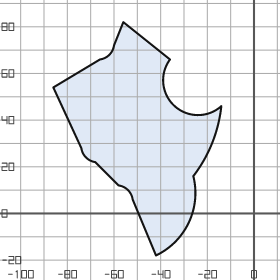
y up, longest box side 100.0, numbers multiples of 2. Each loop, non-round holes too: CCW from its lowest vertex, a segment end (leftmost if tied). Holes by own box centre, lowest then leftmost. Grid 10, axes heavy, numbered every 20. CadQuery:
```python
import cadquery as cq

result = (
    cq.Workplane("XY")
    .moveTo(-42.0, -18.0)
    .threePointArc((-28.0, -4.0), (-26.0, 16.0))
    .threePointArc((-18.0, 30.0), (-14.0, 46.0))
    .threePointArc((-34.0, 46.0), (-36.0, 66.0))
    .lineTo(-56.0, 82.0)
    .lineTo(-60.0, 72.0)
    .threePointArc((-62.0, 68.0), (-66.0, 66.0))
    .lineTo(-86.0, 54.0)
    .lineTo(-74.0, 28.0)
    .threePointArc((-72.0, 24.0), (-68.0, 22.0))
    .lineTo(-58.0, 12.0)
    .threePointArc((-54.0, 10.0), (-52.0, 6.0))
    .close()
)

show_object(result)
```